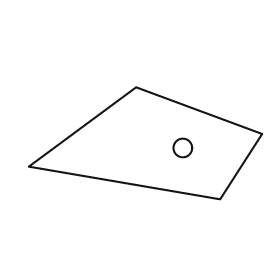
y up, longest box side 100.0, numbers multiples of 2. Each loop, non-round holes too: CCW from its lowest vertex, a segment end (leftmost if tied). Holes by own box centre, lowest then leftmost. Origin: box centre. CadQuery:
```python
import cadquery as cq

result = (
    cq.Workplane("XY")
    .moveTo(32.0, -24.0)
    .lineTo(50.0, 4.0)
    .lineTo(-4.0, 24.0)
    .lineTo(-50.0, -10.0)
    .close()
    .moveTo(16.0, -2.0)
    .circle(4.0)
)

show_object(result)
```